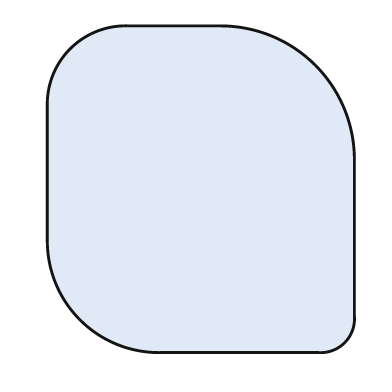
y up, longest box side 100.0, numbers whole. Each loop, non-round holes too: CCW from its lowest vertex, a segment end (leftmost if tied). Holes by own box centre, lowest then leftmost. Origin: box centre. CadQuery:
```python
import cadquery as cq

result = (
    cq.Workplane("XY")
    .moveTo(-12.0, -50.0)
    .lineTo(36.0, -50.0)
    .threePointArc((44.0, -47.0), (47.0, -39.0))
    .lineTo(47.0, 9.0)
    .threePointArc((35.0, 38.0), (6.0, 50.0))
    .lineTo(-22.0, 50.0)
    .threePointArc((-40.0, 43.0), (-47.0, 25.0))
    .lineTo(-47.0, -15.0)
    .threePointArc((-37.0, -40.0), (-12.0, -50.0))
    .close()
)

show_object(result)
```